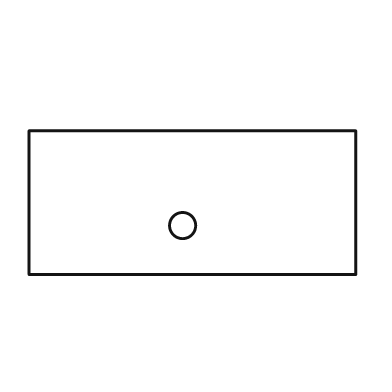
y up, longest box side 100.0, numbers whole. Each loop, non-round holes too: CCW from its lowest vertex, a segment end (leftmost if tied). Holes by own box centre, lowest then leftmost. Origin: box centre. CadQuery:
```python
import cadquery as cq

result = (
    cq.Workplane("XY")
    .moveTo(-50.0, -22.0)
    .lineTo(50.0, -22.0)
    .lineTo(50.0, 22.0)
    .lineTo(-50.0, 22.0)
    .close()
    .moveTo(-3.0, -7.0)
    .circle(4.0)
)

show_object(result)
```